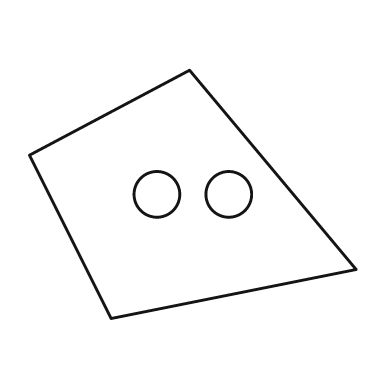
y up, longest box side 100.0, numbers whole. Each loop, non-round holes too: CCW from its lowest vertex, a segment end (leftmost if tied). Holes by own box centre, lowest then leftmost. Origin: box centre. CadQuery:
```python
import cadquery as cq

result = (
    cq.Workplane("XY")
    .moveTo(-25.0, -38.0)
    .lineTo(50.0, -23.0)
    .lineTo(-1.0, 38.0)
    .lineTo(-50.0, 12.0)
    .close()
    .moveTo(-11.0, 0.0)
    .circle(7.0)
    .moveTo(11.0, 0.0)
    .circle(7.0)
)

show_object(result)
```